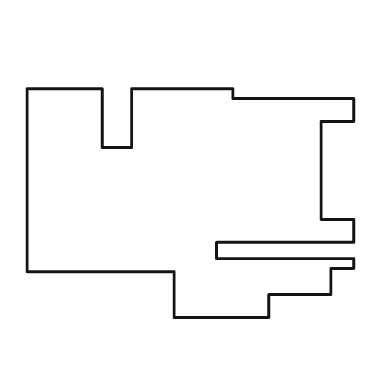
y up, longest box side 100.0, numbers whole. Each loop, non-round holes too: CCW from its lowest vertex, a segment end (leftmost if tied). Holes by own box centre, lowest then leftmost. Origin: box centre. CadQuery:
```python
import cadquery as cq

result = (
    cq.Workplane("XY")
    .moveTo(-5.0, -35.0)
    .lineTo(24.0, -35.0)
    .lineTo(24.0, -28.0)
    .lineTo(43.0, -28.0)
    .lineTo(43.0, -20.0)
    .lineTo(50.0, -20.0)
    .lineTo(50.0, -17.0)
    .lineTo(8.0, -17.0)
    .lineTo(8.0, -12.0)
    .lineTo(50.0, -12.0)
    .lineTo(50.0, -5.0)
    .lineTo(40.0, -5.0)
    .lineTo(40.0, 25.0)
    .lineTo(50.0, 25.0)
    .lineTo(50.0, 32.0)
    .lineTo(13.0, 32.0)
    .lineTo(13.0, 35.0)
    .lineTo(-18.0, 35.0)
    .lineTo(-18.0, 17.0)
    .lineTo(-27.0, 17.0)
    .lineTo(-27.0, 35.0)
    .lineTo(-50.0, 35.0)
    .lineTo(-50.0, -21.0)
    .lineTo(-5.0, -21.0)
    .close()
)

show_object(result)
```